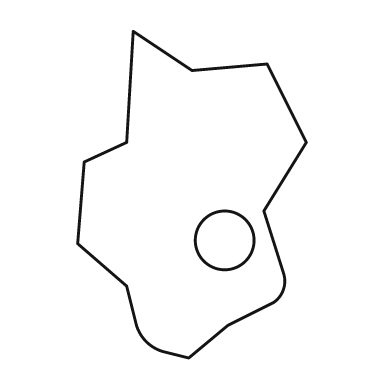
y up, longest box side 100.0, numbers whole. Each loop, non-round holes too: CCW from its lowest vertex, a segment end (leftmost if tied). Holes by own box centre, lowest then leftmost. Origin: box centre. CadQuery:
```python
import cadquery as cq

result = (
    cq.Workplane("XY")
    .moveTo(-1.0, -50.0)
    .lineTo(11.0, -40.0)
    .lineTo(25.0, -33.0)
    .threePointArc((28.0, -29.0), (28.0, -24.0))
    .lineTo(22.0, -5.0)
    .lineTo(35.0, 16.0)
    .lineTo(23.0, 40.0)
    .lineTo(0.0, 38.0)
    .lineTo(-18.0, 50.0)
    .lineTo(-20.0, 16.0)
    .lineTo(-33.0, 10.0)
    .lineTo(-35.0, -15.0)
    .lineTo(-20.0, -28.0)
    .lineTo(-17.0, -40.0)
    .threePointArc((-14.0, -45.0), (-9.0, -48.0))
    .close()
    .moveTo(10.0, -14.0)
    .circle(9.0)
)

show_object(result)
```